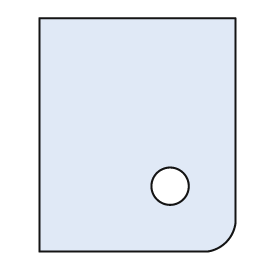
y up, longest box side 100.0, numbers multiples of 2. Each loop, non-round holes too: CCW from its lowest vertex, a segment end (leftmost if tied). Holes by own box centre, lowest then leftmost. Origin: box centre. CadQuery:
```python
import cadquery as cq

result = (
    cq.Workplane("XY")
    .moveTo(-42.0, -50.0)
    .lineTo(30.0, -50.0)
    .threePointArc((38.0, -46.0), (42.0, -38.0))
    .lineTo(42.0, 50.0)
    .lineTo(-42.0, 50.0)
    .close()
    .moveTo(14.0, -22.0)
    .circle(8.0)
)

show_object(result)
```